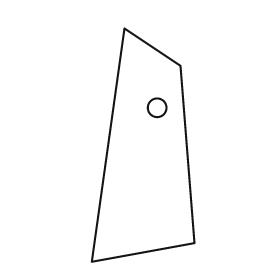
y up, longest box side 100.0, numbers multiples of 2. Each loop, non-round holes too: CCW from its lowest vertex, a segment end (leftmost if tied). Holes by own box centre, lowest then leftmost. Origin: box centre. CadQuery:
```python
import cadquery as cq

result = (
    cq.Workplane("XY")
    .moveTo(-22.0, -50.0)
    .lineTo(22.0, -42.0)
    .lineTo(16.0, 34.0)
    .lineTo(-8.0, 50.0)
    .close()
    .moveTo(6.0, 16.0)
    .circle(4.0)
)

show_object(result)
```